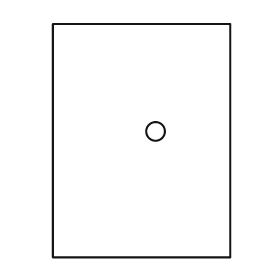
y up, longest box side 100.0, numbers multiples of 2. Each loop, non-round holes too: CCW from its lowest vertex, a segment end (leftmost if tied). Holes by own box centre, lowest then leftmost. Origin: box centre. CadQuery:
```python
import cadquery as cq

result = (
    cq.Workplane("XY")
    .moveTo(-38.0, -50.0)
    .lineTo(38.0, -50.0)
    .lineTo(38.0, 50.0)
    .lineTo(-38.0, 50.0)
    .close()
    .moveTo(6.0, 4.0)
    .circle(4.0)
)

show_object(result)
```